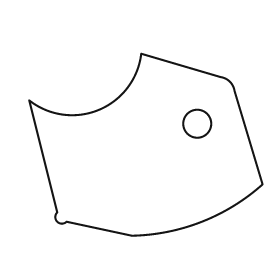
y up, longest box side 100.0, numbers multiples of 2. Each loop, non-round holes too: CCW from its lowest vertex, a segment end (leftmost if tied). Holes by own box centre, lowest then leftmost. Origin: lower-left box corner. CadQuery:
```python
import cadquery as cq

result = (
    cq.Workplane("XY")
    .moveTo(44.0, 0.0)
    .threePointArc((74.0, 6.0), (100.0, 22.0))
    .lineTo(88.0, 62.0)
    .threePointArc((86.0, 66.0), (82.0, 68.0))
    .lineTo(48.0, 78.0)
    .threePointArc((30.0, 54.0), (0.0, 58.0))
    .lineTo(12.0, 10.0)
    .threePointArc((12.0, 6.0), (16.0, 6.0))
    .close()
    .moveTo(72.0, 48.0)
    .circle(6.0)
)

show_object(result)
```